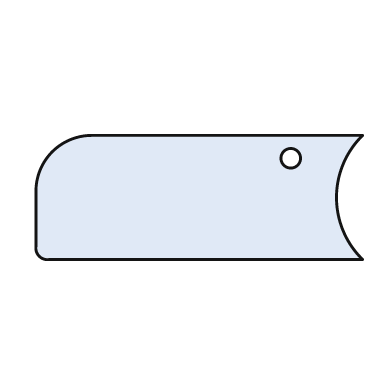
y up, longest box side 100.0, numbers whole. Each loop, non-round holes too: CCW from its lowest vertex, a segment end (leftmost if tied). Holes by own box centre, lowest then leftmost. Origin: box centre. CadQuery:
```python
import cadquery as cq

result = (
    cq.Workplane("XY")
    .moveTo(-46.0, -19.0)
    .lineTo(50.0, -19.0)
    .threePointArc((42.0, 0.0), (50.0, 19.0))
    .lineTo(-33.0, 19.0)
    .threePointArc((-45.0, 14.0), (-50.0, 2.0))
    .lineTo(-50.0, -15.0)
    .threePointArc((-49.0, -18.0), (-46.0, -19.0))
    .close()
    .moveTo(28.0, 12.0)
    .circle(3.0)
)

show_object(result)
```